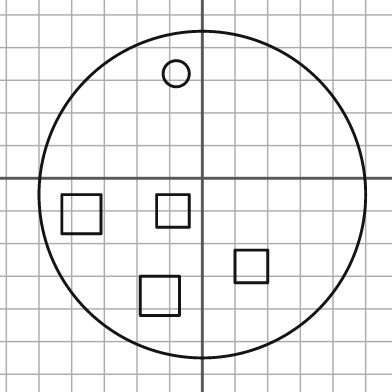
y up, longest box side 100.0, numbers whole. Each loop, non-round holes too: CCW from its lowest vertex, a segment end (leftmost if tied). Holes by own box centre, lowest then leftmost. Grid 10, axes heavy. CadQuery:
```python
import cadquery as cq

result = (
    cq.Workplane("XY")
    .moveTo(0.0, -5.0)
    .circle(50.0)
    .moveTo(-19.0, -42.0)
    .lineTo(-7.0, -42.0)
    .lineTo(-7.0, -30.0)
    .lineTo(-19.0, -30.0)
    .close()
    .moveTo(10.0, -32.0)
    .lineTo(20.0, -32.0)
    .lineTo(20.0, -22.0)
    .lineTo(10.0, -22.0)
    .close()
    .moveTo(-43.0, -17.0)
    .lineTo(-31.0, -17.0)
    .lineTo(-31.0, -5.0)
    .lineTo(-43.0, -5.0)
    .close()
    .moveTo(-14.0, -15.0)
    .lineTo(-4.0, -15.0)
    .lineTo(-4.0, -5.0)
    .lineTo(-14.0, -5.0)
    .close()
    .moveTo(-8.0, 32.0)
    .circle(4.0)
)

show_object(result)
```